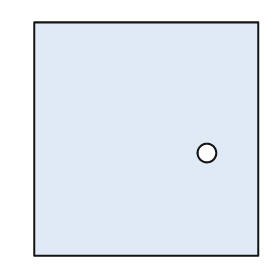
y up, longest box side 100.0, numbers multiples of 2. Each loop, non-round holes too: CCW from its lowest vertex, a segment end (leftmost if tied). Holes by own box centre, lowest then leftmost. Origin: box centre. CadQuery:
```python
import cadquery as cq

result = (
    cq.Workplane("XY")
    .moveTo(-48.0, -50.0)
    .lineTo(48.0, -50.0)
    .lineTo(48.0, 50.0)
    .lineTo(-48.0, 50.0)
    .close()
    .moveTo(26.0, -6.0)
    .circle(4.0)
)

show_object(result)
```